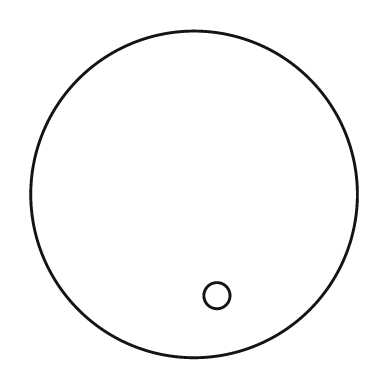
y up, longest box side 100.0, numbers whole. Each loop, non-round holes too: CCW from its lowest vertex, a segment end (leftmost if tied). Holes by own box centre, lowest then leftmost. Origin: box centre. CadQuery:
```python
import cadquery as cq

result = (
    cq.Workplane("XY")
    .moveTo(0.0, 0.0)
    .circle(50.0)
    .moveTo(7.0, -31.0)
    .circle(4.0)
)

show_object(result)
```